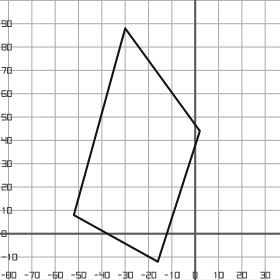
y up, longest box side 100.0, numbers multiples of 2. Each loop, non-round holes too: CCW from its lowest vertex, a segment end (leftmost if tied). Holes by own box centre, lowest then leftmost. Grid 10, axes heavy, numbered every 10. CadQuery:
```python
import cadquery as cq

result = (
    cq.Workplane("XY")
    .moveTo(-16.0, -12.0)
    .lineTo(2.0, 44.0)
    .lineTo(-30.0, 88.0)
    .lineTo(-52.0, 8.0)
    .close()
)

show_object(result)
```